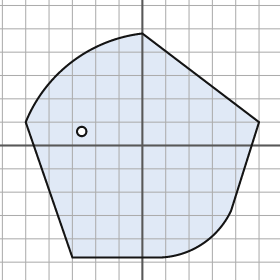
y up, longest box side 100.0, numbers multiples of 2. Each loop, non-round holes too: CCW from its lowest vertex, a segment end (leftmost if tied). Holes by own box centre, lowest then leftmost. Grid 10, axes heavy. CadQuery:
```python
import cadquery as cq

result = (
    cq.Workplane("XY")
    .moveTo(-30.0, -48.0)
    .lineTo(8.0, -48.0)
    .threePointArc((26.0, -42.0), (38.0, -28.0))
    .lineTo(50.0, 10.0)
    .lineTo(0.0, 48.0)
    .threePointArc((-30.0, 36.0), (-50.0, 10.0))
    .close()
    .moveTo(-26.0, 6.0)
    .circle(2.0)
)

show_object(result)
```